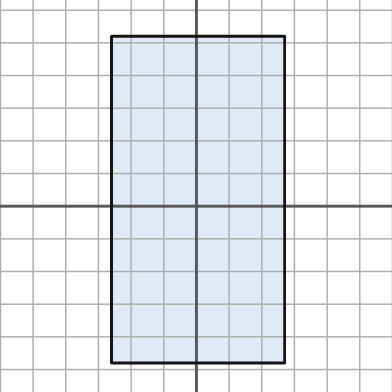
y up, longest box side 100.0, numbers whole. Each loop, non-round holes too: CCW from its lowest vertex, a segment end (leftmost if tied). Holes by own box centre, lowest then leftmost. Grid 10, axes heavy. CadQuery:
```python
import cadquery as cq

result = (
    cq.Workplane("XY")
    .moveTo(-26.0, -48.0)
    .lineTo(27.0, -48.0)
    .lineTo(27.0, 52.0)
    .lineTo(-26.0, 52.0)
    .close()
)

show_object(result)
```